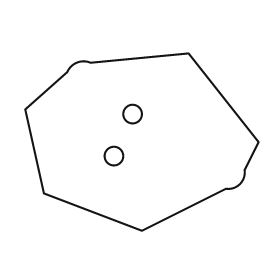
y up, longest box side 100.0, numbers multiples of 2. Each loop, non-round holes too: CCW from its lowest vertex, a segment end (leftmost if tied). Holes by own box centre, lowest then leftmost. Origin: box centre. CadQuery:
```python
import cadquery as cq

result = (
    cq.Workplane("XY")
    .moveTo(0.0, -38.0)
    .lineTo(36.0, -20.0)
    .threePointArc((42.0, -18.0), (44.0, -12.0))
    .lineTo(50.0, 0.0)
    .lineTo(20.0, 38.0)
    .lineTo(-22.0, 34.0)
    .threePointArc((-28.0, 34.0), (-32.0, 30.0))
    .lineTo(-50.0, 14.0)
    .lineTo(-42.0, -22.0)
    .close()
    .moveTo(-12.0, -6.0)
    .circle(4.0)
    .moveTo(-4.0, 12.0)
    .circle(4.0)
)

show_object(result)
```